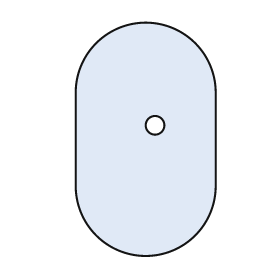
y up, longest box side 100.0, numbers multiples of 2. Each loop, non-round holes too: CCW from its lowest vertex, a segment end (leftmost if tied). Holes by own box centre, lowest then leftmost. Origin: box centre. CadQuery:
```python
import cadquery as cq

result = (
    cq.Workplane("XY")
    .moveTo(-30.0, -20.0)
    .threePointArc((0.0, -50.0), (30.0, -20.0))
    .lineTo(30.0, 20.0)
    .threePointArc((0.0, 50.0), (-30.0, 20.0))
    .close()
    .moveTo(4.0, 6.0)
    .circle(4.0)
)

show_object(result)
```